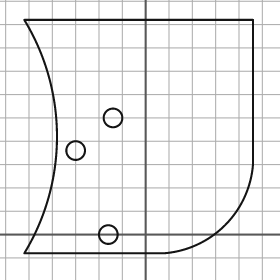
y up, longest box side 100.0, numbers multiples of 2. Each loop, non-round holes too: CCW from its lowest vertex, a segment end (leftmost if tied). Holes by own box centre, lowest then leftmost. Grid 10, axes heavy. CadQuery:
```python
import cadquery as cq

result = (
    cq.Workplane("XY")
    .moveTo(-52.0, -8.0)
    .lineTo(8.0, -8.0)
    .threePointArc((34.0, 4.0), (46.0, 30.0))
    .lineTo(46.0, 92.0)
    .lineTo(-52.0, 92.0)
    .threePointArc((-38.0, 42.0), (-52.0, -8.0))
    .close()
    .moveTo(-16.0, 0.0)
    .circle(4.0)
    .moveTo(-30.0, 36.0)
    .circle(4.0)
    .moveTo(-14.0, 50.0)
    .circle(4.0)
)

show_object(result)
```